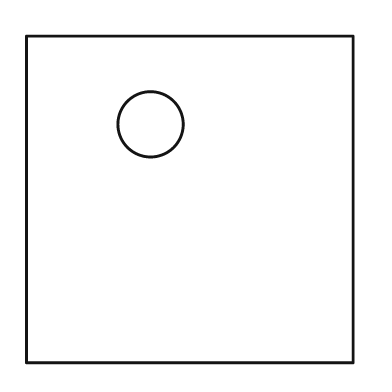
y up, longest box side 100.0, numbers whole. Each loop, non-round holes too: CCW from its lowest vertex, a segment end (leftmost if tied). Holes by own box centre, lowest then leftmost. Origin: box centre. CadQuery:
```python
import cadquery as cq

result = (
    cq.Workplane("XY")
    .moveTo(-50.0, -50.0)
    .lineTo(50.0, -50.0)
    .lineTo(50.0, 50.0)
    .lineTo(-50.0, 50.0)
    .close()
    .moveTo(-12.0, 23.0)
    .circle(10.0)
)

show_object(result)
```